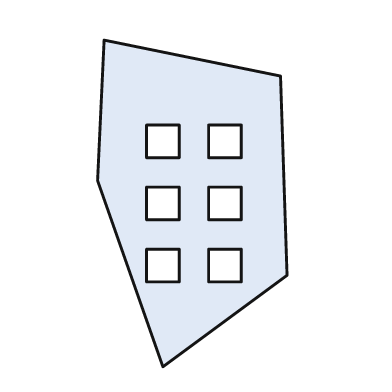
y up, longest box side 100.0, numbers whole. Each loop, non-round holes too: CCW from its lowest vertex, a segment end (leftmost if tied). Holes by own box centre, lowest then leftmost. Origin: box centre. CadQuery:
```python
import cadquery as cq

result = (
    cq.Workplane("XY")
    .moveTo(-9.0, -50.0)
    .lineTo(29.0, -22.0)
    .lineTo(27.0, 39.0)
    .lineTo(-27.0, 50.0)
    .lineTo(-29.0, 7.0)
    .close()
    .moveTo(-14.0, -24.0)
    .lineTo(-4.0, -24.0)
    .lineTo(-4.0, -14.0)
    .lineTo(-14.0, -14.0)
    .close()
    .moveTo(5.0, -24.0)
    .lineTo(15.0, -24.0)
    .lineTo(15.0, -14.0)
    .lineTo(5.0, -14.0)
    .close()
    .moveTo(-14.0, -5.0)
    .lineTo(-4.0, -5.0)
    .lineTo(-4.0, 5.0)
    .lineTo(-14.0, 5.0)
    .close()
    .moveTo(5.0, -5.0)
    .lineTo(15.0, -5.0)
    .lineTo(15.0, 5.0)
    .lineTo(5.0, 5.0)
    .close()
    .moveTo(-14.0, 14.0)
    .lineTo(-4.0, 14.0)
    .lineTo(-4.0, 24.0)
    .lineTo(-14.0, 24.0)
    .close()
    .moveTo(5.0, 14.0)
    .lineTo(15.0, 14.0)
    .lineTo(15.0, 24.0)
    .lineTo(5.0, 24.0)
    .close()
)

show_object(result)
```